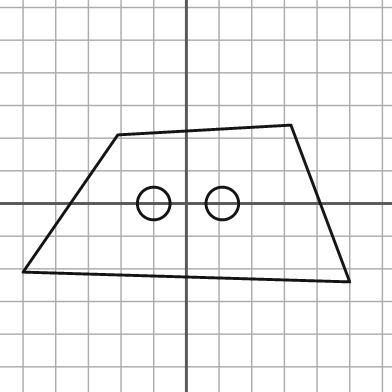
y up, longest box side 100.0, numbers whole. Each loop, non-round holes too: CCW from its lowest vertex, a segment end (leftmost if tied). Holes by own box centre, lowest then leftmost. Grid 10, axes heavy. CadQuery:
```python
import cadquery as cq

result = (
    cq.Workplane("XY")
    .moveTo(50.0, -24.0)
    .lineTo(32.0, 24.0)
    .lineTo(-21.0, 21.0)
    .lineTo(-50.0, -21.0)
    .close()
    .moveTo(-10.0, 0.0)
    .circle(5.0)
    .moveTo(11.0, 0.0)
    .circle(5.0)
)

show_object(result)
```